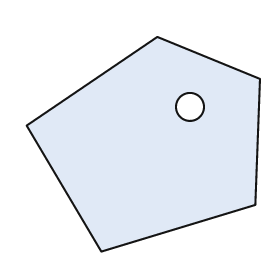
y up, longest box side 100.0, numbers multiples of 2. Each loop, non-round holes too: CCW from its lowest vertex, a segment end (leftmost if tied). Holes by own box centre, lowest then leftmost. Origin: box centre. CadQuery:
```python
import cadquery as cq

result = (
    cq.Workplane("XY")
    .moveTo(-18.0, -46.0)
    .lineTo(48.0, -26.0)
    .lineTo(50.0, 28.0)
    .lineTo(6.0, 46.0)
    .lineTo(-50.0, 8.0)
    .close()
    .moveTo(20.0, 16.0)
    .circle(6.0)
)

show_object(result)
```